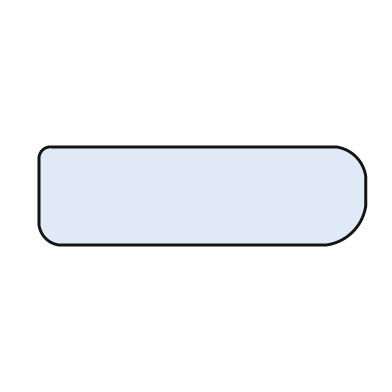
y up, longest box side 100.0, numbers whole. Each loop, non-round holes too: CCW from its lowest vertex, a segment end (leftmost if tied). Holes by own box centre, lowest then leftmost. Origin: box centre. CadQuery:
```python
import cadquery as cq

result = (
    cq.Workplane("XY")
    .moveTo(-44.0, -15.0)
    .lineTo(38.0, -15.0)
    .threePointArc((46.0, -11.0), (50.0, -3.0))
    .lineTo(50.0, 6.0)
    .threePointArc((47.0, 12.0), (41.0, 15.0))
    .lineTo(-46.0, 15.0)
    .threePointArc((-49.0, 14.0), (-50.0, 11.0))
    .lineTo(-50.0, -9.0)
    .threePointArc((-48.0, -13.0), (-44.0, -15.0))
    .close()
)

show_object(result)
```